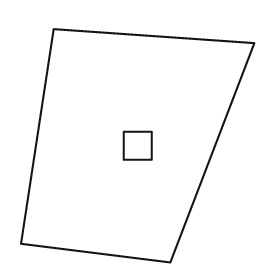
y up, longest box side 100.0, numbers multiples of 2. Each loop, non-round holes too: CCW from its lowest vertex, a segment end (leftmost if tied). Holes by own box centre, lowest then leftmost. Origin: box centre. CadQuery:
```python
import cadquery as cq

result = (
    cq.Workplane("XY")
    .moveTo(14.0, -50.0)
    .lineTo(50.0, 44.0)
    .lineTo(-36.0, 50.0)
    .lineTo(-50.0, -42.0)
    .close()
    .moveTo(-6.0, -6.0)
    .lineTo(6.0, -6.0)
    .lineTo(6.0, 6.0)
    .lineTo(-6.0, 6.0)
    .close()
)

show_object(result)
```